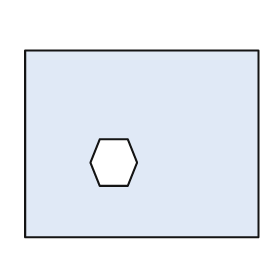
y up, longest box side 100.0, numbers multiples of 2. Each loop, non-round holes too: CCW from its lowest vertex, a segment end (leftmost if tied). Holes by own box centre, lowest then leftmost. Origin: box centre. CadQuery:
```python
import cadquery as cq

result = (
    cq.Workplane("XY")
    .moveTo(-50.0, -40.0)
    .lineTo(50.0, -40.0)
    .lineTo(50.0, 40.0)
    .lineTo(-50.0, 40.0)
    .close()
    .moveTo(-18.0, -18.0)
    .lineTo(-6.0, -18.0)
    .lineTo(-2.0, -8.0)
    .lineTo(-6.0, 2.0)
    .lineTo(-18.0, 2.0)
    .lineTo(-22.0, -8.0)
    .close()
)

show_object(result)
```